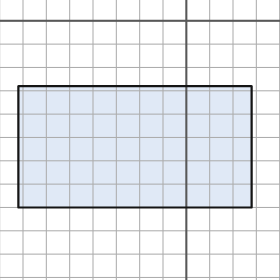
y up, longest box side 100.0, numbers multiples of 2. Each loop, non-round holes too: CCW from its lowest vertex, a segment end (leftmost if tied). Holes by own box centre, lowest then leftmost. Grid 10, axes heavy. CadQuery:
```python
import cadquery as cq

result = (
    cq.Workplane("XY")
    .moveTo(-72.0, -80.0)
    .lineTo(28.0, -80.0)
    .lineTo(28.0, -28.0)
    .lineTo(-72.0, -28.0)
    .close()
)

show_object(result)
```